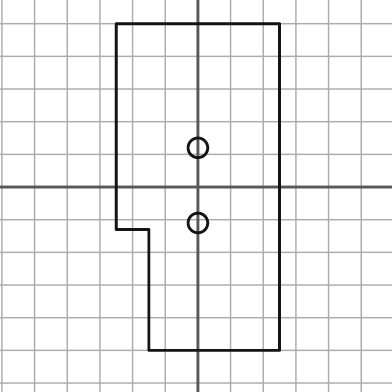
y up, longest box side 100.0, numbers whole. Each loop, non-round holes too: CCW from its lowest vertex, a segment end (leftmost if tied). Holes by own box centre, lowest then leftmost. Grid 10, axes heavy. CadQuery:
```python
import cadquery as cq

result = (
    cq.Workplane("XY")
    .moveTo(-15.0, -50.0)
    .lineTo(25.0, -50.0)
    .lineTo(25.0, 50.0)
    .lineTo(-25.0, 50.0)
    .lineTo(-25.0, -13.0)
    .lineTo(-15.0, -13.0)
    .close()
    .moveTo(0.0, -11.0)
    .circle(3.0)
    .moveTo(0.0, 12.0)
    .circle(3.0)
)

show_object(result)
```